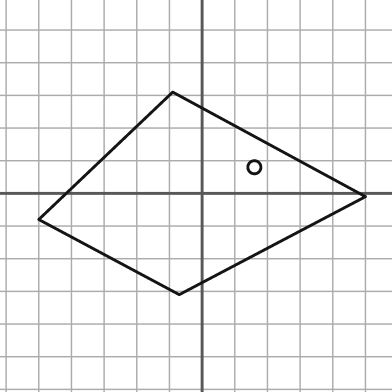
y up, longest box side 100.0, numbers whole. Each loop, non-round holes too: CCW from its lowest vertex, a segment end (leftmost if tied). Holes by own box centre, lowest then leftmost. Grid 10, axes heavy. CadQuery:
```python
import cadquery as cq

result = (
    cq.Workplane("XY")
    .moveTo(-7.0, -31.0)
    .lineTo(50.0, -1.0)
    .lineTo(-9.0, 31.0)
    .lineTo(-50.0, -8.0)
    .close()
    .moveTo(16.0, 8.0)
    .circle(2.0)
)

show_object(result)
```